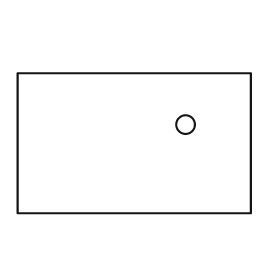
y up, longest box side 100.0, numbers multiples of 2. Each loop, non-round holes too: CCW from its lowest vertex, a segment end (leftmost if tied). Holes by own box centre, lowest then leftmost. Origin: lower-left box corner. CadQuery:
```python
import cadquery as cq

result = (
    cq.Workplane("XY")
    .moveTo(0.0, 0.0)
    .lineTo(100.0, 0.0)
    .lineTo(100.0, 60.0)
    .lineTo(0.0, 60.0)
    .close()
    .moveTo(72.0, 38.0)
    .circle(4.0)
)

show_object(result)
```